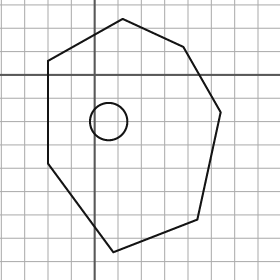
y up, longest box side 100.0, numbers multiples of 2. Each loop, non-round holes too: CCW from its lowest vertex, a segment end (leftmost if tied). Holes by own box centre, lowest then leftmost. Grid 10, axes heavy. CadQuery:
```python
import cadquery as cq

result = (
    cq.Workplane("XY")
    .moveTo(8.0, -76.0)
    .lineTo(44.0, -62.0)
    .lineTo(54.0, -16.0)
    .lineTo(38.0, 12.0)
    .lineTo(12.0, 24.0)
    .lineTo(-20.0, 6.0)
    .lineTo(-20.0, -38.0)
    .close()
    .moveTo(6.0, -20.0)
    .circle(8.0)
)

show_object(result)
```